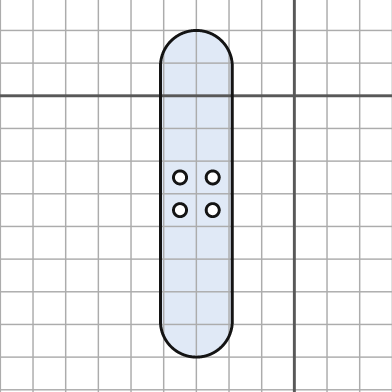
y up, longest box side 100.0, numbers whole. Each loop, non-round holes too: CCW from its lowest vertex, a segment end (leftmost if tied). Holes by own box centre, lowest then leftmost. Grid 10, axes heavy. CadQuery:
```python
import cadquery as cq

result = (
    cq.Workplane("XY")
    .moveTo(-41.0, -69.0)
    .threePointArc((-30.0, -80.0), (-19.0, -69.0))
    .lineTo(-19.0, 9.0)
    .threePointArc((-30.0, 20.0), (-41.0, 9.0))
    .close()
    .moveTo(-35.0, -35.0)
    .circle(2.0)
    .moveTo(-25.0, -35.0)
    .circle(2.0)
    .moveTo(-35.0, -25.0)
    .circle(2.0)
    .moveTo(-25.0, -25.0)
    .circle(2.0)
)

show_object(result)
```